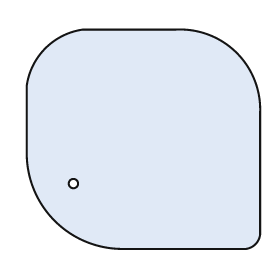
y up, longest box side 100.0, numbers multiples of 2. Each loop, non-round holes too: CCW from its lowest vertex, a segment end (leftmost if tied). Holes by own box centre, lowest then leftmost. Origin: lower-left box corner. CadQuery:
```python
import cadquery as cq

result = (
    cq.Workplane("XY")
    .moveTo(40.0, 0.0)
    .lineTo(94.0, 0.0)
    .threePointArc((98.0, 2.0), (100.0, 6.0))
    .lineTo(100.0, 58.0)
    .threePointArc((90.0, 84.0), (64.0, 94.0))
    .lineTo(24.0, 94.0)
    .threePointArc((8.0, 86.0), (0.0, 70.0))
    .lineTo(0.0, 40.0)
    .threePointArc((12.0, 12.0), (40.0, 0.0))
    .close()
    .moveTo(20.0, 28.0)
    .circle(2.0)
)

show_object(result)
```